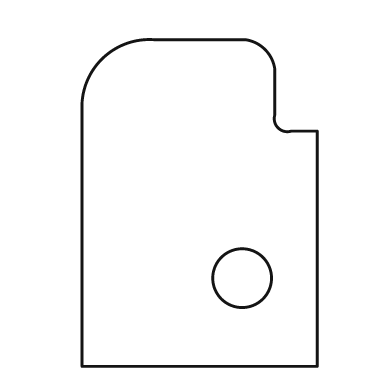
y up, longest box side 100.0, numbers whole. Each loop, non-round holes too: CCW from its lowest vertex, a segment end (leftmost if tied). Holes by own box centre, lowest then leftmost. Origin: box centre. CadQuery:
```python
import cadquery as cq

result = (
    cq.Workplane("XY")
    .moveTo(-36.0, -50.0)
    .lineTo(36.0, -50.0)
    .lineTo(36.0, 22.0)
    .lineTo(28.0, 22.0)
    .threePointArc((24.0, 23.0), (23.0, 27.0))
    .lineTo(23.0, 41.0)
    .threePointArc((20.0, 47.0), (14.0, 50.0))
    .lineTo(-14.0, 50.0)
    .threePointArc((-30.0, 44.0), (-36.0, 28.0))
    .close()
    .moveTo(13.0, -23.0)
    .circle(9.0)
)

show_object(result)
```